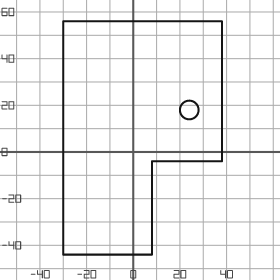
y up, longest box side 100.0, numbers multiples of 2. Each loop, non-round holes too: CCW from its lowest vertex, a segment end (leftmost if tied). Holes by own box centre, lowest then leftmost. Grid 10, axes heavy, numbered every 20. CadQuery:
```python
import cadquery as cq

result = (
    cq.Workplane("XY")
    .moveTo(-30.0, -44.0)
    .lineTo(8.0, -44.0)
    .lineTo(8.0, -4.0)
    .lineTo(38.0, -4.0)
    .lineTo(38.0, 56.0)
    .lineTo(-30.0, 56.0)
    .close()
    .moveTo(24.0, 18.0)
    .circle(4.0)
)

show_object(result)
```